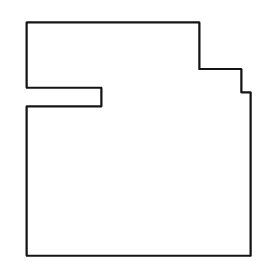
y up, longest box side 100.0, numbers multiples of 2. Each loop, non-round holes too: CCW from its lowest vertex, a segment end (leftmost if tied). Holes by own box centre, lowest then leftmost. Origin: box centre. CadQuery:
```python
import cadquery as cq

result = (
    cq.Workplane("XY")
    .moveTo(-48.0, -50.0)
    .lineTo(48.0, -50.0)
    .lineTo(48.0, 20.0)
    .lineTo(44.0, 20.0)
    .lineTo(44.0, 30.0)
    .lineTo(26.0, 30.0)
    .lineTo(26.0, 50.0)
    .lineTo(-48.0, 50.0)
    .lineTo(-48.0, 22.0)
    .lineTo(-16.0, 22.0)
    .lineTo(-16.0, 14.0)
    .lineTo(-48.0, 14.0)
    .close()
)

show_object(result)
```